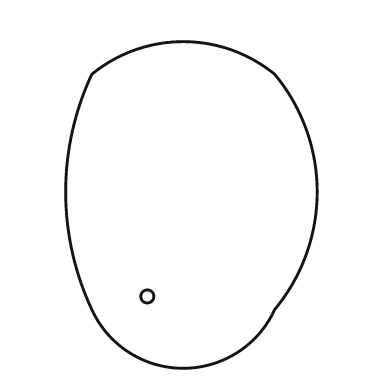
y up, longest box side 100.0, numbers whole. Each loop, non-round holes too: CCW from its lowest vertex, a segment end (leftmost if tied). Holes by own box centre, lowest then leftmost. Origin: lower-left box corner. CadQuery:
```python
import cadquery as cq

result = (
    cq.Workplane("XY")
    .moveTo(8.0, 18.0)
    .threePointArc((36.0, 0.0), (64.0, 18.0))
    .threePointArc((77.0, 54.0), (64.0, 90.0))
    .threePointArc((36.0, 100.0), (8.0, 90.0))
    .threePointArc((0.0, 54.0), (8.0, 18.0))
    .close()
    .moveTo(25.0, 22.0)
    .circle(2.0)
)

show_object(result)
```